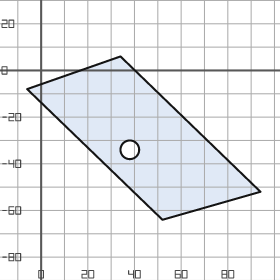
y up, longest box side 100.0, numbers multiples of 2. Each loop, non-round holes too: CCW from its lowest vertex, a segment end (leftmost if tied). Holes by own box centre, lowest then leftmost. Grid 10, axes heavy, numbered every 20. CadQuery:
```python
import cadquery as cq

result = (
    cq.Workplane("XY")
    .moveTo(52.0, -64.0)
    .lineTo(94.0, -52.0)
    .lineTo(34.0, 6.0)
    .lineTo(-6.0, -8.0)
    .close()
    .moveTo(38.0, -34.0)
    .circle(4.0)
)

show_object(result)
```